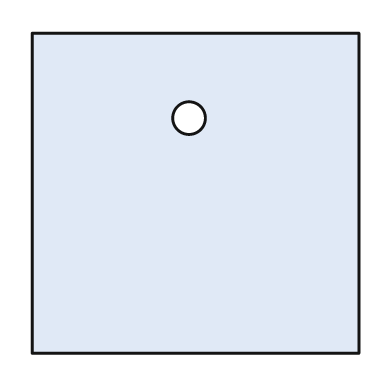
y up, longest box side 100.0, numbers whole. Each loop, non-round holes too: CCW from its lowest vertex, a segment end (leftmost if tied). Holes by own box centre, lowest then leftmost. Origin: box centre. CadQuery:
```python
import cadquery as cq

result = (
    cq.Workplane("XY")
    .moveTo(-50.0, -49.0)
    .lineTo(50.0, -49.0)
    .lineTo(50.0, 49.0)
    .lineTo(-50.0, 49.0)
    .close()
    .moveTo(-2.0, 23.0)
    .circle(5.0)
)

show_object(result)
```